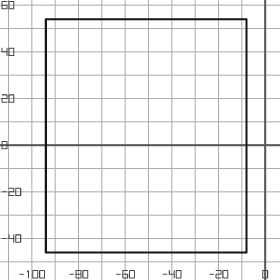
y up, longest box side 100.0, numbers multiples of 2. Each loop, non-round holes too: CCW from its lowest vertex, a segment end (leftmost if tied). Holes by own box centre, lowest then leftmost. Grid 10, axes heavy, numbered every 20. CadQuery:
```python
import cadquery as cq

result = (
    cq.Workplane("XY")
    .moveTo(-94.0, -46.0)
    .lineTo(-8.0, -46.0)
    .lineTo(-8.0, 54.0)
    .lineTo(-94.0, 54.0)
    .close()
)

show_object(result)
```